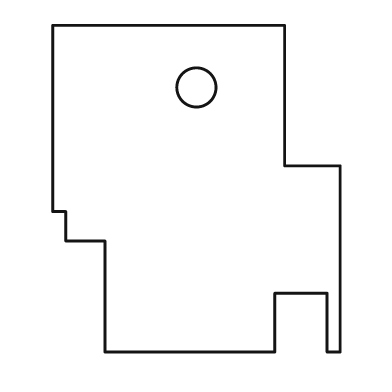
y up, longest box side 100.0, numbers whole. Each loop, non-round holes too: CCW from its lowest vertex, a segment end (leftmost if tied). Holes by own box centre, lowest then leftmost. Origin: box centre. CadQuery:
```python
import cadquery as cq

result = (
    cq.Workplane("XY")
    .moveTo(-28.0, -50.0)
    .lineTo(24.0, -50.0)
    .lineTo(24.0, -32.0)
    .lineTo(40.0, -32.0)
    .lineTo(40.0, -50.0)
    .lineTo(44.0, -50.0)
    .lineTo(44.0, 7.0)
    .lineTo(27.0, 7.0)
    .lineTo(27.0, 50.0)
    .lineTo(-44.0, 50.0)
    .lineTo(-44.0, -7.0)
    .lineTo(-40.0, -7.0)
    .lineTo(-40.0, -16.0)
    .lineTo(-28.0, -16.0)
    .close()
    .moveTo(0.0, 31.0)
    .circle(6.0)
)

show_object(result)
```